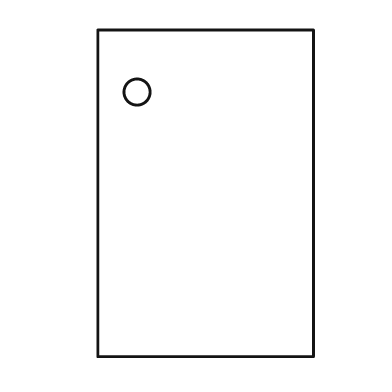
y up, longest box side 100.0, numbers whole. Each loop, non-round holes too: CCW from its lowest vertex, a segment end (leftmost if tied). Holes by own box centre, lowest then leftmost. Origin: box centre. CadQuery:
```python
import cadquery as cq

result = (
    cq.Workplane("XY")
    .moveTo(-33.0, -50.0)
    .lineTo(33.0, -50.0)
    .lineTo(33.0, 50.0)
    .lineTo(-33.0, 50.0)
    .close()
    .moveTo(-21.0, 31.0)
    .circle(4.0)
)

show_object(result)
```